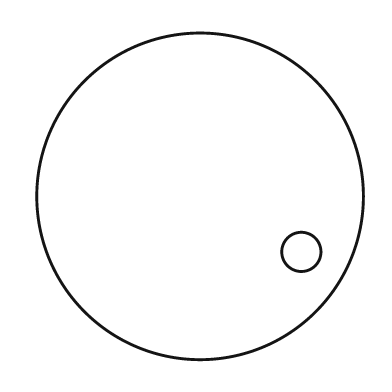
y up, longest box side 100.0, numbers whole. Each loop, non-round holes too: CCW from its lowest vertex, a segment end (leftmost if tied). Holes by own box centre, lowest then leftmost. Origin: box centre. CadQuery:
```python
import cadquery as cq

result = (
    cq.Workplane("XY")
    .moveTo(0.0, 0.0)
    .circle(50.0)
    .moveTo(31.0, -17.0)
    .circle(6.0)
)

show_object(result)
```